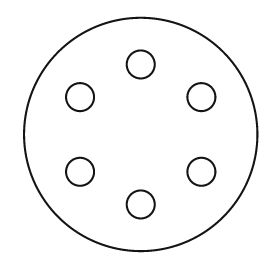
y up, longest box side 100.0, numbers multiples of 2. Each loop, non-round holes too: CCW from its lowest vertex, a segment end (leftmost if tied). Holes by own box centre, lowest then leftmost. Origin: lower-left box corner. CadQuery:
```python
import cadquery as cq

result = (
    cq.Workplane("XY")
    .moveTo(50.0, 50.0)
    .circle(50.0)
    .moveTo(50.0, 20.0)
    .circle(6.0)
    .moveTo(24.0, 34.0)
    .circle(6.0)
    .moveTo(76.0, 34.0)
    .circle(6.0)
    .moveTo(24.0, 66.0)
    .circle(6.0)
    .moveTo(76.0, 66.0)
    .circle(6.0)
    .moveTo(50.0, 80.0)
    .circle(6.0)
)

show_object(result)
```